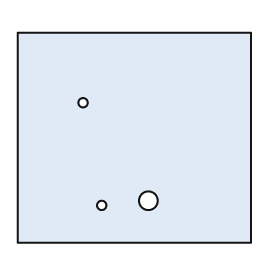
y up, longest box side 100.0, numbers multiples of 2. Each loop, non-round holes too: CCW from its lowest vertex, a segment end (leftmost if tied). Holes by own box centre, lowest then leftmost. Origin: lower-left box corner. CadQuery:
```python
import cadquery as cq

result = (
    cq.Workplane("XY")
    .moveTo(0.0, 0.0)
    .lineTo(100.0, 0.0)
    .lineTo(100.0, 90.0)
    .lineTo(0.0, 90.0)
    .close()
    .moveTo(36.0, 16.0)
    .circle(2.0)
    .moveTo(56.0, 18.0)
    .circle(4.0)
    .moveTo(28.0, 60.0)
    .circle(2.0)
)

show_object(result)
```